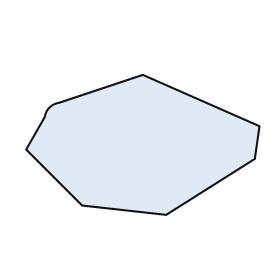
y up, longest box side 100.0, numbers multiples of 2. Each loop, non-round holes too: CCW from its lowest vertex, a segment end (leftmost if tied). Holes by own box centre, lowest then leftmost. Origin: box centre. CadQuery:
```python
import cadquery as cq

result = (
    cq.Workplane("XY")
    .moveTo(10.0, -30.0)
    .lineTo(48.0, -6.0)
    .lineTo(50.0, 8.0)
    .lineTo(0.0, 30.0)
    .lineTo(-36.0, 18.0)
    .threePointArc((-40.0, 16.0), (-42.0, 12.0))
    .lineTo(-50.0, -2.0)
    .lineTo(-26.0, -26.0)
    .close()
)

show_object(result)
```